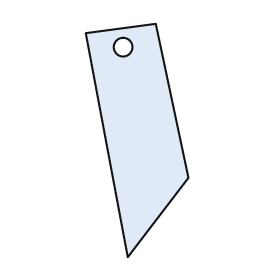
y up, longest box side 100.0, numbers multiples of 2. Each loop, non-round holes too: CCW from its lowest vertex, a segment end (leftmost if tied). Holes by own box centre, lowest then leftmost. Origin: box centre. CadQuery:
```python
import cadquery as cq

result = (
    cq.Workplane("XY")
    .moveTo(-4.0, -50.0)
    .lineTo(22.0, -16.0)
    .lineTo(8.0, 50.0)
    .lineTo(-22.0, 46.0)
    .close()
    .moveTo(-6.0, 40.0)
    .circle(4.0)
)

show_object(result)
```